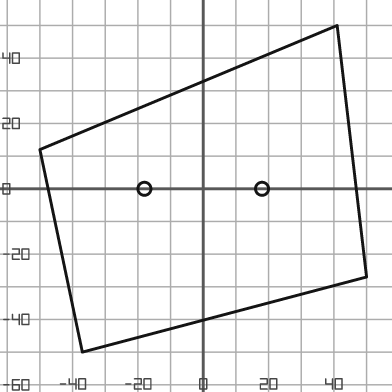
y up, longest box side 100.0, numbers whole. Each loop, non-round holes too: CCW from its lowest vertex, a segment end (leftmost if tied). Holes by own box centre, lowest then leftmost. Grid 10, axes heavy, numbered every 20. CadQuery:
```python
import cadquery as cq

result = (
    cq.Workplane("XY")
    .moveTo(-37.0, -50.0)
    .lineTo(50.0, -27.0)
    .lineTo(41.0, 50.0)
    .lineTo(-50.0, 12.0)
    .close()
    .moveTo(-18.0, 0.0)
    .circle(2.0)
    .moveTo(18.0, 0.0)
    .circle(2.0)
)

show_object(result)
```